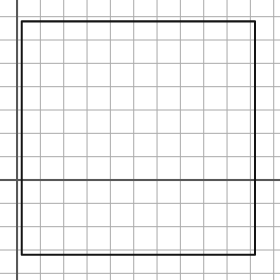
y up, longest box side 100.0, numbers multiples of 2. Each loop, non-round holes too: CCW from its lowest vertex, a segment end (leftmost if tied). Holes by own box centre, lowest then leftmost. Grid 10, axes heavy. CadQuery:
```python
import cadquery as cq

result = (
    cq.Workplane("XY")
    .moveTo(2.0, -32.0)
    .lineTo(102.0, -32.0)
    .lineTo(102.0, 68.0)
    .lineTo(2.0, 68.0)
    .close()
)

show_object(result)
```